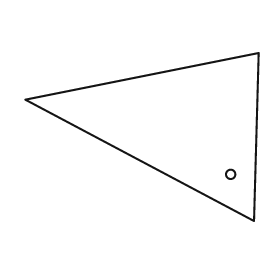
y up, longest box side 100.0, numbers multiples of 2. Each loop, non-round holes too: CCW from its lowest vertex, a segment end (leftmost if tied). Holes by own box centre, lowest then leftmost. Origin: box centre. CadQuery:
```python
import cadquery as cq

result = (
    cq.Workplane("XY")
    .moveTo(48.0, -36.0)
    .lineTo(50.0, 36.0)
    .lineTo(-50.0, 16.0)
    .close()
    .moveTo(38.0, -16.0)
    .circle(2.0)
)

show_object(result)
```